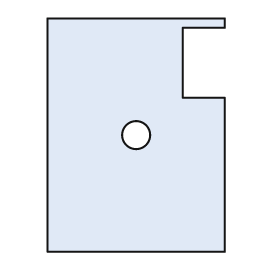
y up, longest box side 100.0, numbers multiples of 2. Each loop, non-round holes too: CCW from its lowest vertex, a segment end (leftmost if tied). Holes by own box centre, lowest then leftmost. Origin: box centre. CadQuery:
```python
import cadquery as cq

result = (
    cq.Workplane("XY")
    .moveTo(-38.0, -50.0)
    .lineTo(38.0, -50.0)
    .lineTo(38.0, 16.0)
    .lineTo(20.0, 16.0)
    .lineTo(20.0, 46.0)
    .lineTo(38.0, 46.0)
    .lineTo(38.0, 50.0)
    .lineTo(-38.0, 50.0)
    .close()
    .moveTo(0.0, 0.0)
    .circle(6.0)
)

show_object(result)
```